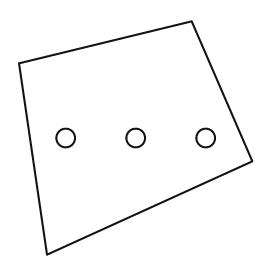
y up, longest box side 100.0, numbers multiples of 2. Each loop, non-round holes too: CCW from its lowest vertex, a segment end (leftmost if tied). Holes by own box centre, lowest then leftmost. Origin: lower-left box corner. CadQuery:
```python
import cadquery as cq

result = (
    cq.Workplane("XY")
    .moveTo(12.0, 0.0)
    .lineTo(100.0, 40.0)
    .lineTo(74.0, 100.0)
    .lineTo(0.0, 82.0)
    .close()
    .moveTo(20.0, 50.0)
    .circle(4.0)
    .moveTo(50.0, 50.0)
    .circle(4.0)
    .moveTo(80.0, 50.0)
    .circle(4.0)
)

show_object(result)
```